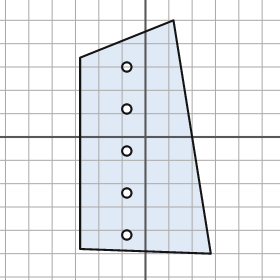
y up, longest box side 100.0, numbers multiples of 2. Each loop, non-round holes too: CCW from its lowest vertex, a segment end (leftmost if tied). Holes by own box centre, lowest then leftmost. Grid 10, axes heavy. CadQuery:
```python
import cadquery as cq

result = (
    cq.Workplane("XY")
    .moveTo(28.0, -50.0)
    .lineTo(12.0, 50.0)
    .lineTo(-28.0, 34.0)
    .lineTo(-28.0, -48.0)
    .close()
    .moveTo(-8.0, -42.0)
    .circle(2.0)
    .moveTo(-8.0, -24.0)
    .circle(2.0)
    .moveTo(-8.0, -6.0)
    .circle(2.0)
    .moveTo(-8.0, 12.0)
    .circle(2.0)
    .moveTo(-8.0, 30.0)
    .circle(2.0)
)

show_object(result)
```